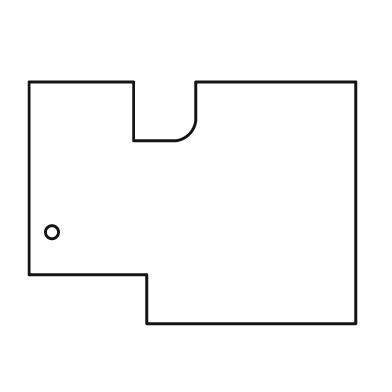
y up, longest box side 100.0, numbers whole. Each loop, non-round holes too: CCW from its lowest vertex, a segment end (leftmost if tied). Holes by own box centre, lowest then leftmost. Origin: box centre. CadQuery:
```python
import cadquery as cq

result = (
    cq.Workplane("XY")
    .moveTo(-14.0, -37.0)
    .lineTo(50.0, -37.0)
    .lineTo(50.0, 37.0)
    .lineTo(1.0, 37.0)
    .lineTo(1.0, 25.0)
    .threePointArc((-1.0, 21.0), (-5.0, 19.0))
    .lineTo(-18.0, 19.0)
    .lineTo(-18.0, 37.0)
    .lineTo(-50.0, 37.0)
    .lineTo(-50.0, -22.0)
    .lineTo(-14.0, -22.0)
    .close()
    .moveTo(-43.0, -9.0)
    .circle(2.0)
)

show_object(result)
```